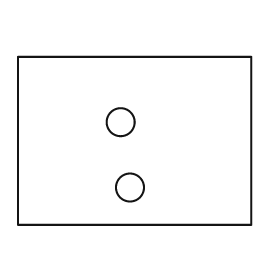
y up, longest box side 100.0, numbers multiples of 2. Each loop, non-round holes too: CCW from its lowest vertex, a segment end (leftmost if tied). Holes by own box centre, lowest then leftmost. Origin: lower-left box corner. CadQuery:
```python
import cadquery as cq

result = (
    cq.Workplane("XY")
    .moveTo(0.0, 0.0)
    .lineTo(100.0, 0.0)
    .lineTo(100.0, 72.0)
    .lineTo(0.0, 72.0)
    .close()
    .moveTo(48.0, 16.0)
    .circle(6.0)
    .moveTo(44.0, 44.0)
    .circle(6.0)
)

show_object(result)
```